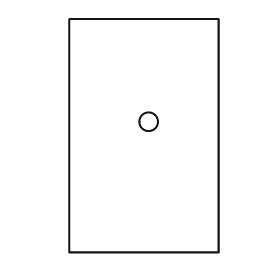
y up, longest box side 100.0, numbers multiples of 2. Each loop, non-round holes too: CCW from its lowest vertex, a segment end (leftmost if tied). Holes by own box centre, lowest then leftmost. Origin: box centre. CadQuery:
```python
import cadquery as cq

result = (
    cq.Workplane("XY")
    .moveTo(-32.0, -50.0)
    .lineTo(32.0, -50.0)
    .lineTo(32.0, 50.0)
    .lineTo(-32.0, 50.0)
    .close()
    .moveTo(2.0, 6.0)
    .circle(4.0)
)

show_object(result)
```